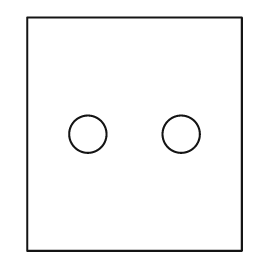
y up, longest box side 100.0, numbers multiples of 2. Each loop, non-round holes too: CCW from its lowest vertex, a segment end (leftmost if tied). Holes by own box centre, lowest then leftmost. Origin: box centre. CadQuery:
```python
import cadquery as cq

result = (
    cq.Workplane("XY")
    .moveTo(-46.0, -50.0)
    .lineTo(46.0, -50.0)
    .lineTo(46.0, 50.0)
    .lineTo(-46.0, 50.0)
    .close()
    .moveTo(-20.0, 0.0)
    .circle(8.0)
    .moveTo(20.0, 0.0)
    .circle(8.0)
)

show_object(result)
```